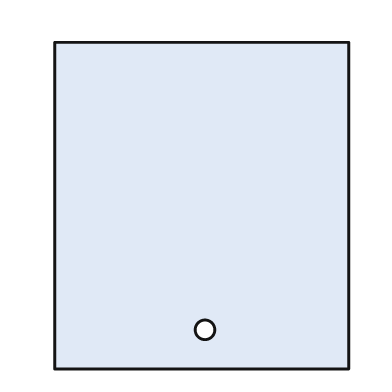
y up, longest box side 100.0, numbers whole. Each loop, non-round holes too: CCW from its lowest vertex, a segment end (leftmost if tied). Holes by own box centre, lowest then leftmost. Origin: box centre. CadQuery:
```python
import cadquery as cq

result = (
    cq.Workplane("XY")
    .moveTo(-45.0, -50.0)
    .lineTo(45.0, -50.0)
    .lineTo(45.0, 50.0)
    .lineTo(-45.0, 50.0)
    .close()
    .moveTo(1.0, -38.0)
    .circle(3.0)
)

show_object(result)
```